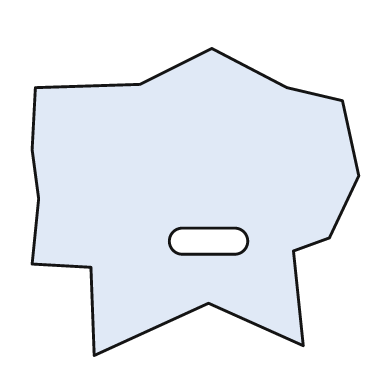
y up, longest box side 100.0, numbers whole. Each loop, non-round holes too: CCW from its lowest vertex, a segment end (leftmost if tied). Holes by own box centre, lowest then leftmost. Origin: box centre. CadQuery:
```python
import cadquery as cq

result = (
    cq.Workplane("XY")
    .moveTo(-31.0, -47.0)
    .lineTo(4.0, -31.0)
    .lineTo(33.0, -44.0)
    .lineTo(30.0, -15.0)
    .lineTo(41.0, -11.0)
    .lineTo(50.0, 8.0)
    .lineTo(45.0, 31.0)
    .lineTo(28.0, 35.0)
    .lineTo(5.0, 47.0)
    .lineTo(-17.0, 36.0)
    .lineTo(-49.0, 35.0)
    .lineTo(-50.0, 16.0)
    .lineTo(-48.0, 1.0)
    .lineTo(-50.0, -19.0)
    .lineTo(-32.0, -20.0)
    .close()
    .moveTo(-4.0, -16.0)
    .lineTo(12.0, -16.0)
    .threePointArc((16.0, -12.0), (12.0, -8.0))
    .lineTo(-4.0, -8.0)
    .threePointArc((-8.0, -12.0), (-4.0, -16.0))
    .close()
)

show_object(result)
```